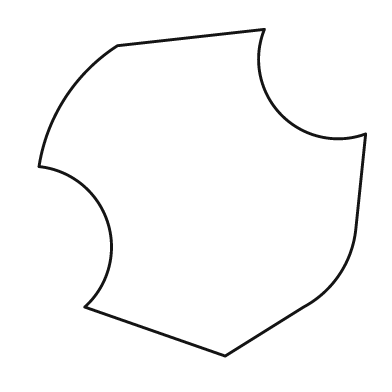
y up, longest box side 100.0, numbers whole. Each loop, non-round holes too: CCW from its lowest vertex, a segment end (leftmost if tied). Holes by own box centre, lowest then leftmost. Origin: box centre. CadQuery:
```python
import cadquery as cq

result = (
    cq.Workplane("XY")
    .moveTo(7.0, -50.0)
    .lineTo(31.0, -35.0)
    .threePointArc((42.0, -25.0), (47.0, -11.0))
    .lineTo(50.0, 18.0)
    .threePointArc((24.0, 24.0), (19.0, 50.0))
    .lineTo(-26.0, 45.0)
    .threePointArc((-42.0, 29.0), (-50.0, 8.0))
    .threePointArc((-29.0, -9.0), (-36.0, -35.0))
    .close()
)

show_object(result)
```